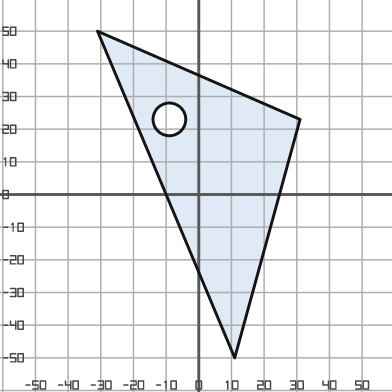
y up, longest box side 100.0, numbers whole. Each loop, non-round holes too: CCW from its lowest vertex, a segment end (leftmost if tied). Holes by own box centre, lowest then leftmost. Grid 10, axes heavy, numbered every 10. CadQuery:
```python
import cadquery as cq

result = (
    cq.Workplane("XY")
    .moveTo(11.0, -50.0)
    .lineTo(31.0, 23.0)
    .lineTo(-31.0, 50.0)
    .close()
    .moveTo(-9.0, 23.0)
    .circle(5.0)
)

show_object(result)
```